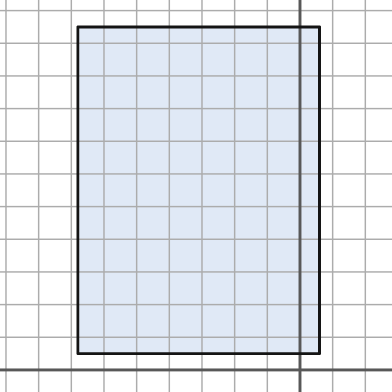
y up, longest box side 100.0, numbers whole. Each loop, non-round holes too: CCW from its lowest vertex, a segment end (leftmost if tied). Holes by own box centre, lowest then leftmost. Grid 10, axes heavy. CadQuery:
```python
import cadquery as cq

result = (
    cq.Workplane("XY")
    .moveTo(-68.0, 5.0)
    .lineTo(6.0, 5.0)
    .lineTo(6.0, 105.0)
    .lineTo(-68.0, 105.0)
    .close()
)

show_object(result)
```